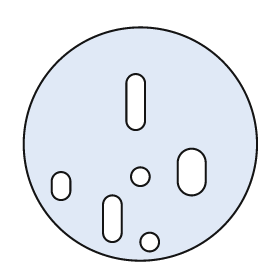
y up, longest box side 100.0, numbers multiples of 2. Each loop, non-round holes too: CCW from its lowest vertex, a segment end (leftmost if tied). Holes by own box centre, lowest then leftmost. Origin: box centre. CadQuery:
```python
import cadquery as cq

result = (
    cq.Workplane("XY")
    .moveTo(0.0, 0.0)
    .circle(50.0)
    .moveTo(4.0, -42.0)
    .circle(4.0)
    .moveTo(-16.0, -38.0)
    .threePointArc((-12.0, -42.0), (-8.0, -38.0))
    .lineTo(-8.0, -26.0)
    .threePointArc((-12.0, -22.0), (-16.0, -26.0))
    .close()
    .moveTo(-38.0, -20.0)
    .threePointArc((-34.0, -24.0), (-30.0, -20.0))
    .lineTo(-30.0, -16.0)
    .threePointArc((-34.0, -12.0), (-38.0, -16.0))
    .close()
    .moveTo(0.0, -14.0)
    .circle(4.0)
    .moveTo(16.0, -16.0)
    .threePointArc((22.0, -22.0), (28.0, -16.0))
    .lineTo(28.0, -8.0)
    .threePointArc((22.0, -2.0), (16.0, -8.0))
    .close()
    .moveTo(-6.0, 10.0)
    .threePointArc((-2.0, 6.0), (2.0, 10.0))
    .lineTo(2.0, 26.0)
    .threePointArc((-2.0, 30.0), (-6.0, 26.0))
    .close()
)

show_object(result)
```